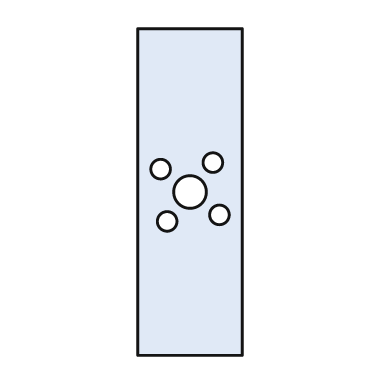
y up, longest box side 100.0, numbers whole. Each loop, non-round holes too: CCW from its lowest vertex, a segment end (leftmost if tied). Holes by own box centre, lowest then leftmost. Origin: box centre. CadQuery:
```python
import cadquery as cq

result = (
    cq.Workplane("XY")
    .moveTo(-16.0, -50.0)
    .lineTo(16.0, -50.0)
    .lineTo(16.0, 50.0)
    .lineTo(-16.0, 50.0)
    .close()
    .moveTo(-7.0, -9.0)
    .circle(3.0)
    .moveTo(9.0, -7.0)
    .circle(3.0)
    .moveTo(0.0, 0.0)
    .circle(5.0)
    .moveTo(-9.0, 7.0)
    .circle(3.0)
    .moveTo(7.0, 9.0)
    .circle(3.0)
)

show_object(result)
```